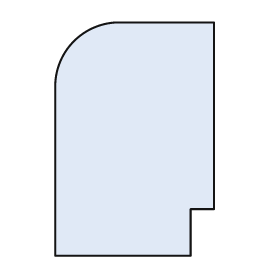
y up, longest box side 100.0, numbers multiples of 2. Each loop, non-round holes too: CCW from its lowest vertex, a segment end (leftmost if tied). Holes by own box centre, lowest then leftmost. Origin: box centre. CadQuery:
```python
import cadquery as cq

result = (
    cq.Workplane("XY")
    .moveTo(-34.0, -50.0)
    .lineTo(24.0, -50.0)
    .lineTo(24.0, -30.0)
    .lineTo(34.0, -30.0)
    .lineTo(34.0, 50.0)
    .lineTo(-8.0, 50.0)
    .threePointArc((-26.0, 42.0), (-34.0, 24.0))
    .close()
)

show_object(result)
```